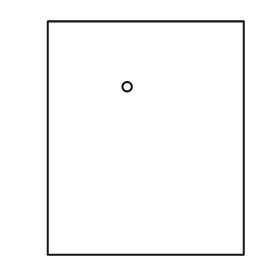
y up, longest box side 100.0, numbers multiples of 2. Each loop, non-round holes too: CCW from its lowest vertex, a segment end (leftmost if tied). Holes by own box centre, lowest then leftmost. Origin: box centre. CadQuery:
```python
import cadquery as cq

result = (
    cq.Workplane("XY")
    .moveTo(-42.0, -50.0)
    .lineTo(42.0, -50.0)
    .lineTo(42.0, 50.0)
    .lineTo(-42.0, 50.0)
    .close()
    .moveTo(-8.0, 22.0)
    .circle(2.0)
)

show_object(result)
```